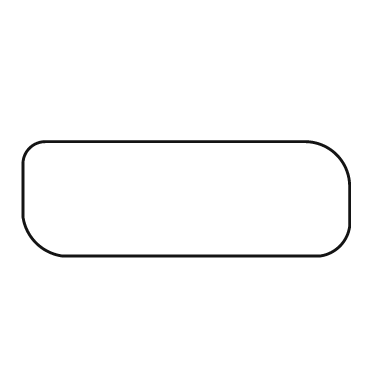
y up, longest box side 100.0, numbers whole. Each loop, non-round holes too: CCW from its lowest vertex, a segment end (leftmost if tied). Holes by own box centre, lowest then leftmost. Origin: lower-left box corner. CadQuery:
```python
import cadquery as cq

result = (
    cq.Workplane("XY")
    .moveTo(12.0, 0.0)
    .lineTo(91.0, 0.0)
    .threePointArc((97.0, 3.0), (100.0, 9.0))
    .lineTo(100.0, 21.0)
    .threePointArc((96.0, 31.0), (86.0, 35.0))
    .lineTo(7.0, 35.0)
    .threePointArc((2.0, 33.0), (0.0, 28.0))
    .lineTo(0.0, 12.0)
    .threePointArc((4.0, 4.0), (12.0, 0.0))
    .close()
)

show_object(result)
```